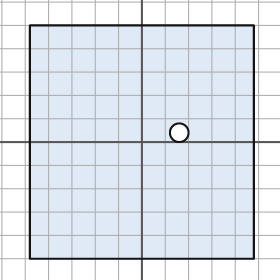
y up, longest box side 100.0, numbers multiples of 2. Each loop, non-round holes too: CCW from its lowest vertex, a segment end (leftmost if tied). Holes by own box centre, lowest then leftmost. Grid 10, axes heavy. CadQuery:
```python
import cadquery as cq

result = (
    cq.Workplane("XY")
    .moveTo(-48.0, -50.0)
    .lineTo(48.0, -50.0)
    .lineTo(48.0, 50.0)
    .lineTo(-48.0, 50.0)
    .close()
    .moveTo(16.0, 4.0)
    .circle(4.0)
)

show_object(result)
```